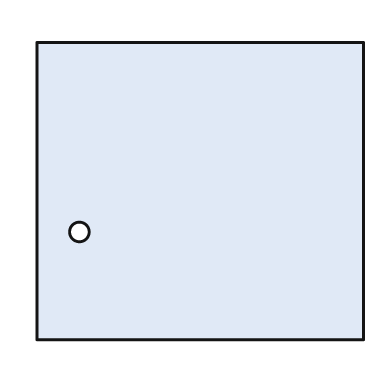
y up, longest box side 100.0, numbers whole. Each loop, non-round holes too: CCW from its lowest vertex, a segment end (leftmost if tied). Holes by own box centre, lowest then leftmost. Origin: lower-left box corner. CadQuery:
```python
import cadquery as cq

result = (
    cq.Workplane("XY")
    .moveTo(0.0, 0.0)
    .lineTo(100.0, 0.0)
    .lineTo(100.0, 91.0)
    .lineTo(0.0, 91.0)
    .close()
    .moveTo(13.0, 33.0)
    .circle(3.0)
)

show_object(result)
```